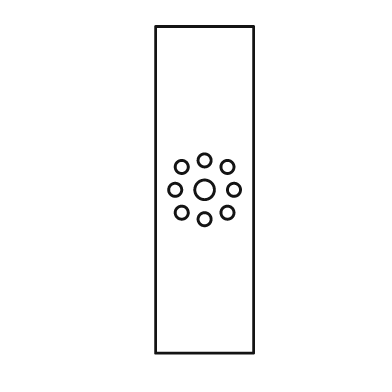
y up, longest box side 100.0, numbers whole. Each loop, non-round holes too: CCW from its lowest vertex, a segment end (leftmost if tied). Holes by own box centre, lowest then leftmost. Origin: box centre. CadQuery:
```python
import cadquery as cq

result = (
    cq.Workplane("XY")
    .moveTo(-15.0, -50.0)
    .lineTo(15.0, -50.0)
    .lineTo(15.0, 50.0)
    .lineTo(-15.0, 50.0)
    .close()
    .moveTo(0.0, -9.0)
    .circle(2.0)
    .moveTo(-7.0, -7.0)
    .circle(2.0)
    .moveTo(7.0, -7.0)
    .circle(2.0)
    .moveTo(-9.0, 0.0)
    .circle(2.0)
    .moveTo(0.0, 0.0)
    .circle(3.0)
    .moveTo(9.0, 0.0)
    .circle(2.0)
    .moveTo(-7.0, 7.0)
    .circle(2.0)
    .moveTo(7.0, 7.0)
    .circle(2.0)
    .moveTo(0.0, 9.0)
    .circle(2.0)
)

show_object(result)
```